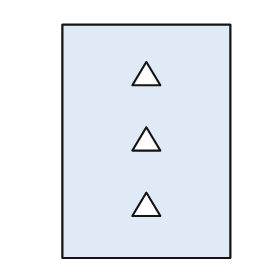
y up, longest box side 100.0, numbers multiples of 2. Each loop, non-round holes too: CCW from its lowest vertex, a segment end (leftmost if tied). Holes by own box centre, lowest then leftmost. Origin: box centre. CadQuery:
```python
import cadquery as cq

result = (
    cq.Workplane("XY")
    .moveTo(-36.0, -50.0)
    .lineTo(36.0, -50.0)
    .lineTo(36.0, 50.0)
    .lineTo(-36.0, 50.0)
    .close()
    .moveTo(-6.0, -32.0)
    .lineTo(6.0, -32.0)
    .lineTo(0.0, -22.0)
    .close()
    .moveTo(-6.0, -4.0)
    .lineTo(6.0, -4.0)
    .lineTo(0.0, 6.0)
    .close()
    .moveTo(-6.0, 24.0)
    .lineTo(6.0, 24.0)
    .lineTo(0.0, 34.0)
    .close()
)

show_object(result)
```